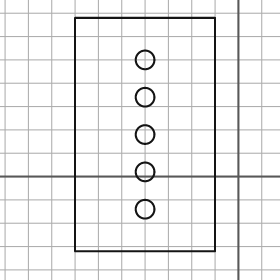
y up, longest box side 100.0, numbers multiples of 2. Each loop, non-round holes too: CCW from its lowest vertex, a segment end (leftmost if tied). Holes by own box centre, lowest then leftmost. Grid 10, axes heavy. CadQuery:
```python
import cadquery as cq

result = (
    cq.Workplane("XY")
    .moveTo(-70.0, -32.0)
    .lineTo(-10.0, -32.0)
    .lineTo(-10.0, 68.0)
    .lineTo(-70.0, 68.0)
    .close()
    .moveTo(-40.0, -14.0)
    .circle(4.0)
    .moveTo(-40.0, 2.0)
    .circle(4.0)
    .moveTo(-40.0, 18.0)
    .circle(4.0)
    .moveTo(-40.0, 34.0)
    .circle(4.0)
    .moveTo(-40.0, 50.0)
    .circle(4.0)
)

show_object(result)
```